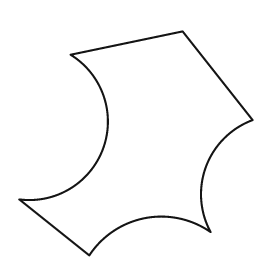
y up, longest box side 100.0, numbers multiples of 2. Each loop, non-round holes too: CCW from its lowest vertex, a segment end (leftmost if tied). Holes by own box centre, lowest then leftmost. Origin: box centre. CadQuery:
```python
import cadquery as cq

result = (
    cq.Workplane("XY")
    .moveTo(-20.0, -48.0)
    .threePointArc((4.0, -32.0), (32.0, -38.0))
    .threePointArc((30.0, -10.0), (50.0, 10.0))
    .lineTo(20.0, 48.0)
    .lineTo(-28.0, 38.0)
    .threePointArc((-14.0, -2.0), (-50.0, -24.0))
    .close()
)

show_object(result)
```